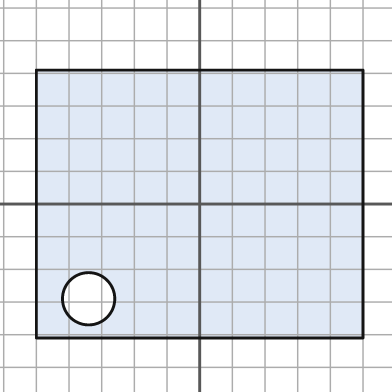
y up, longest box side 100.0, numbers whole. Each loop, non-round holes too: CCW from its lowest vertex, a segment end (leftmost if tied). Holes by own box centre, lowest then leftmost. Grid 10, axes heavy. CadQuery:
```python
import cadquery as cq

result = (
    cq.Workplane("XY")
    .moveTo(-50.0, -41.0)
    .lineTo(50.0, -41.0)
    .lineTo(50.0, 41.0)
    .lineTo(-50.0, 41.0)
    .close()
    .moveTo(-34.0, -29.0)
    .circle(8.0)
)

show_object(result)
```